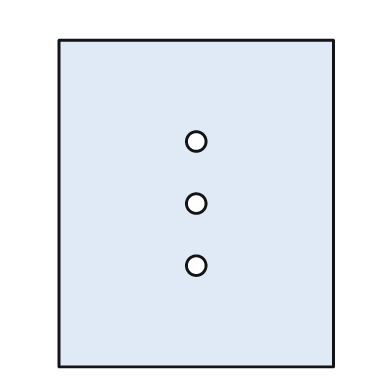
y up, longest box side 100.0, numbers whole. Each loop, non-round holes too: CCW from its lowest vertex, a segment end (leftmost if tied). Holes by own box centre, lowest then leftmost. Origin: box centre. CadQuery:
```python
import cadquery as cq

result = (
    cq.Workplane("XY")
    .moveTo(-42.0, -50.0)
    .lineTo(42.0, -50.0)
    .lineTo(42.0, 50.0)
    .lineTo(-42.0, 50.0)
    .close()
    .moveTo(0.0, -19.0)
    .circle(3.0)
    .moveTo(0.0, 0.0)
    .circle(3.0)
    .moveTo(0.0, 19.0)
    .circle(3.0)
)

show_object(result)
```